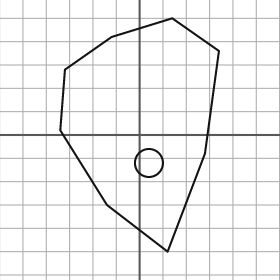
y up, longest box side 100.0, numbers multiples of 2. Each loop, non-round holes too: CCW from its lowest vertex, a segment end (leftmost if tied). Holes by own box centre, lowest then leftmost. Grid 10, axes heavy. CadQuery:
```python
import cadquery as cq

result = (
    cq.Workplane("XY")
    .moveTo(12.0, -50.0)
    .lineTo(28.0, -8.0)
    .lineTo(34.0, 36.0)
    .lineTo(14.0, 50.0)
    .lineTo(-12.0, 42.0)
    .lineTo(-32.0, 28.0)
    .lineTo(-34.0, 2.0)
    .lineTo(-14.0, -30.0)
    .close()
    .moveTo(4.0, -12.0)
    .circle(6.0)
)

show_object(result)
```